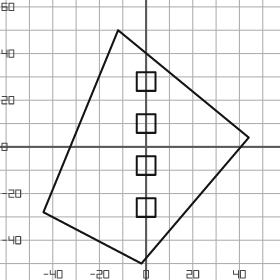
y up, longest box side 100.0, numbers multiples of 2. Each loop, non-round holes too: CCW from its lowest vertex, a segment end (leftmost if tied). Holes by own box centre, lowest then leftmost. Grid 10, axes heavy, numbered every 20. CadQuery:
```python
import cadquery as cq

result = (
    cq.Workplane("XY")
    .moveTo(-2.0, -50.0)
    .lineTo(44.0, 4.0)
    .lineTo(-12.0, 50.0)
    .lineTo(-44.0, -28.0)
    .close()
    .moveTo(-4.0, -30.0)
    .lineTo(4.0, -30.0)
    .lineTo(4.0, -22.0)
    .lineTo(-4.0, -22.0)
    .close()
    .moveTo(-4.0, -12.0)
    .lineTo(4.0, -12.0)
    .lineTo(4.0, -4.0)
    .lineTo(-4.0, -4.0)
    .close()
    .moveTo(-4.0, 6.0)
    .lineTo(4.0, 6.0)
    .lineTo(4.0, 14.0)
    .lineTo(-4.0, 14.0)
    .close()
    .moveTo(-4.0, 24.0)
    .lineTo(4.0, 24.0)
    .lineTo(4.0, 32.0)
    .lineTo(-4.0, 32.0)
    .close()
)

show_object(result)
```